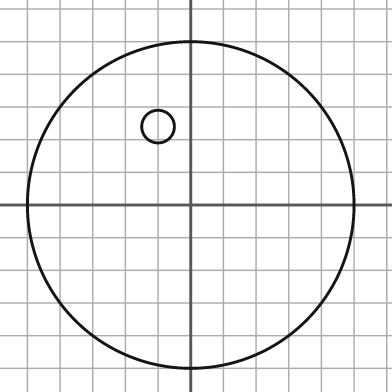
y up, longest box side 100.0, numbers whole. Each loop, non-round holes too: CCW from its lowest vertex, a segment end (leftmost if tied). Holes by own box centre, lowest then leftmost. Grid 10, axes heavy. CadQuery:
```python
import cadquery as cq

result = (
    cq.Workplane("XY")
    .moveTo(0.0, 0.0)
    .circle(50.0)
    .moveTo(-10.0, 24.0)
    .circle(5.0)
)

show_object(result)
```